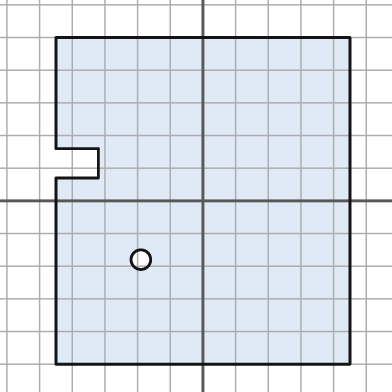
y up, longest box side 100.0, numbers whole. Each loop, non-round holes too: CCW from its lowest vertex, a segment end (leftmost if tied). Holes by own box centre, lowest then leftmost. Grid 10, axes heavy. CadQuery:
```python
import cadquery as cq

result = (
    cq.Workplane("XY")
    .moveTo(-45.0, -50.0)
    .lineTo(45.0, -50.0)
    .lineTo(45.0, 50.0)
    .lineTo(-45.0, 50.0)
    .lineTo(-45.0, 16.0)
    .lineTo(-32.0, 16.0)
    .lineTo(-32.0, 7.0)
    .lineTo(-45.0, 7.0)
    .close()
    .moveTo(-19.0, -18.0)
    .circle(3.0)
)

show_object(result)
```